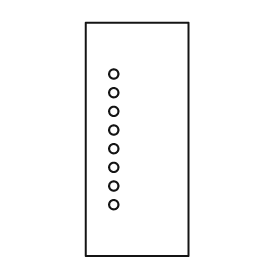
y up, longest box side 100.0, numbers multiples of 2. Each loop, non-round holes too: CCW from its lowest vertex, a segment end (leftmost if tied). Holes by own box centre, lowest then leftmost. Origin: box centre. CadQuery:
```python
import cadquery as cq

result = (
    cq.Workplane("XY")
    .moveTo(-22.0, -50.0)
    .lineTo(22.0, -50.0)
    .lineTo(22.0, 50.0)
    .lineTo(-22.0, 50.0)
    .close()
    .moveTo(-10.0, -28.0)
    .circle(2.0)
    .moveTo(-10.0, -20.0)
    .circle(2.0)
    .moveTo(-10.0, -12.0)
    .circle(2.0)
    .moveTo(-10.0, -4.0)
    .circle(2.0)
    .moveTo(-10.0, 4.0)
    .circle(2.0)
    .moveTo(-10.0, 12.0)
    .circle(2.0)
    .moveTo(-10.0, 20.0)
    .circle(2.0)
    .moveTo(-10.0, 28.0)
    .circle(2.0)
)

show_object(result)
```